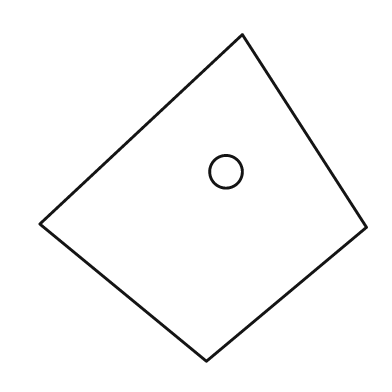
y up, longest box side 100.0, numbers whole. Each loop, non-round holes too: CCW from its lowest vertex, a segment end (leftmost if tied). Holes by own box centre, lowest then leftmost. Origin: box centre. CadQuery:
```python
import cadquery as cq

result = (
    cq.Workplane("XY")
    .moveTo(1.0, -50.0)
    .lineTo(50.0, -9.0)
    .lineTo(12.0, 50.0)
    .lineTo(-50.0, -8.0)
    .close()
    .moveTo(7.0, 8.0)
    .circle(5.0)
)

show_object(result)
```